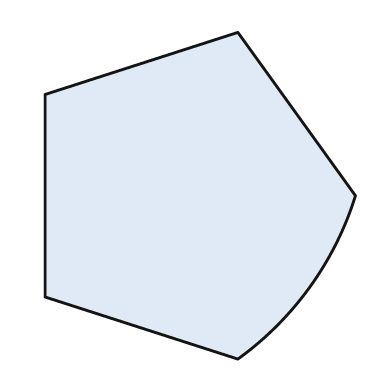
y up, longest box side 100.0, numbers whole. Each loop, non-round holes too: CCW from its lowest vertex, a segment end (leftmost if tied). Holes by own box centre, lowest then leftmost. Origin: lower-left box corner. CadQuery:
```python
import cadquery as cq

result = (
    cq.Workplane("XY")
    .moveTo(59.0, 0.0)
    .threePointArc((81.0, 22.0), (95.0, 50.0))
    .lineTo(59.0, 100.0)
    .lineTo(0.0, 81.0)
    .lineTo(0.0, 19.0)
    .close()
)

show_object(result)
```